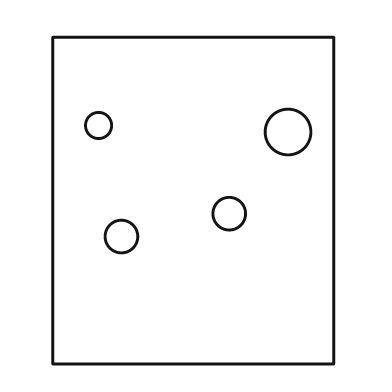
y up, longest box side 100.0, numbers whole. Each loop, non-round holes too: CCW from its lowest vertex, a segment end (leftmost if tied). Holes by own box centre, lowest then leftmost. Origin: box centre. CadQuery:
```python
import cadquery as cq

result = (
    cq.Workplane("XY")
    .moveTo(-43.0, -50.0)
    .lineTo(43.0, -50.0)
    .lineTo(43.0, 50.0)
    .lineTo(-43.0, 50.0)
    .close()
    .moveTo(-22.0, -11.0)
    .circle(5.0)
    .moveTo(11.0, -4.0)
    .circle(5.0)
    .moveTo(29.0, 21.0)
    .circle(7.0)
    .moveTo(-29.0, 23.0)
    .circle(4.0)
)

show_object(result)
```